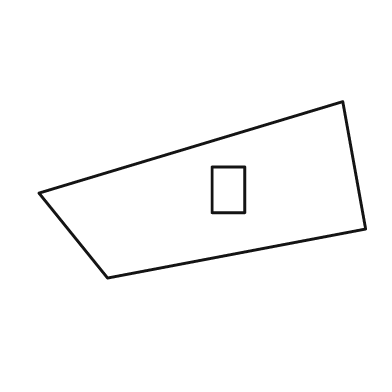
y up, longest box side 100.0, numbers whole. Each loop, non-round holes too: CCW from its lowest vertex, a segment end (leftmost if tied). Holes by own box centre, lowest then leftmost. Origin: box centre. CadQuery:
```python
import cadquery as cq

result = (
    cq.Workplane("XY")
    .moveTo(-29.0, -27.0)
    .lineTo(50.0, -12.0)
    .lineTo(43.0, 27.0)
    .lineTo(-50.0, -1.0)
    .close()
    .moveTo(3.0, -7.0)
    .lineTo(13.0, -7.0)
    .lineTo(13.0, 7.0)
    .lineTo(3.0, 7.0)
    .close()
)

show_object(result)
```